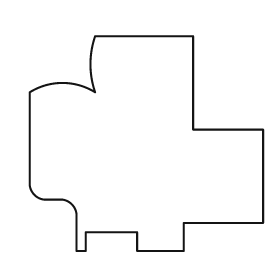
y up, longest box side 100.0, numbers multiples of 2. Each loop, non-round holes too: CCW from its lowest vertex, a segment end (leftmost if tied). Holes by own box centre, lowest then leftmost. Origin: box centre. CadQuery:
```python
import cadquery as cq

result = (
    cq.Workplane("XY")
    .moveTo(-30.0, -46.0)
    .lineTo(-26.0, -46.0)
    .lineTo(-26.0, -38.0)
    .lineTo(-4.0, -38.0)
    .lineTo(-4.0, -46.0)
    .lineTo(16.0, -46.0)
    .lineTo(16.0, -34.0)
    .lineTo(50.0, -34.0)
    .lineTo(50.0, 6.0)
    .lineTo(20.0, 6.0)
    .lineTo(20.0, 46.0)
    .lineTo(-22.0, 46.0)
    .threePointArc((-24.0, 34.0), (-22.0, 22.0))
    .threePointArc((-36.0, 26.0), (-50.0, 22.0))
    .lineTo(-50.0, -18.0)
    .threePointArc((-48.0, -22.0), (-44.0, -24.0))
    .lineTo(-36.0, -24.0)
    .threePointArc((-32.0, -26.0), (-30.0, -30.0))
    .close()
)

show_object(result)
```